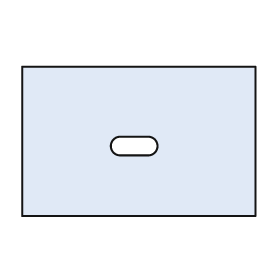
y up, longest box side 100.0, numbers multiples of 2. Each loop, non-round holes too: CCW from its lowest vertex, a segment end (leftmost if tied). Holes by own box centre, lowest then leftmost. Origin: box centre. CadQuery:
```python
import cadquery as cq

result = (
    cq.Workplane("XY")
    .moveTo(-50.0, -32.0)
    .lineTo(50.0, -32.0)
    .lineTo(50.0, 32.0)
    .lineTo(-50.0, 32.0)
    .close()
    .moveTo(-8.0, -6.0)
    .lineTo(4.0, -6.0)
    .threePointArc((8.0, -2.0), (4.0, 2.0))
    .lineTo(-8.0, 2.0)
    .threePointArc((-12.0, -2.0), (-8.0, -6.0))
    .close()
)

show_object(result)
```